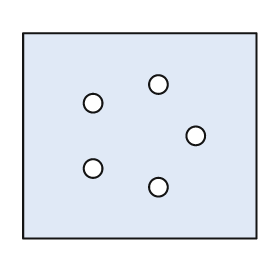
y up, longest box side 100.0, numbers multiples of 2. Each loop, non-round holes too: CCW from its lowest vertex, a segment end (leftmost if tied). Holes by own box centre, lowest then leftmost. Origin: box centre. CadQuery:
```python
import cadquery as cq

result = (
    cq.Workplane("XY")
    .moveTo(-50.0, -44.0)
    .lineTo(50.0, -44.0)
    .lineTo(50.0, 44.0)
    .lineTo(-50.0, 44.0)
    .close()
    .moveTo(8.0, -22.0)
    .circle(4.0)
    .moveTo(-20.0, -14.0)
    .circle(4.0)
    .moveTo(24.0, 0.0)
    .circle(4.0)
    .moveTo(-20.0, 14.0)
    .circle(4.0)
    .moveTo(8.0, 22.0)
    .circle(4.0)
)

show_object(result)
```